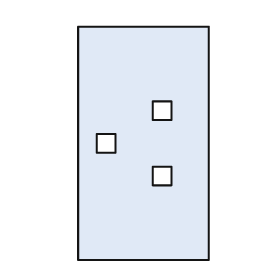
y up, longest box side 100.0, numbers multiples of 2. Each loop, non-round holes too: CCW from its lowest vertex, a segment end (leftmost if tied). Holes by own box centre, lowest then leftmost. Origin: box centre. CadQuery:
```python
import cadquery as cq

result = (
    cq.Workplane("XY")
    .moveTo(-28.0, -50.0)
    .lineTo(28.0, -50.0)
    .lineTo(28.0, 50.0)
    .lineTo(-28.0, 50.0)
    .close()
    .moveTo(4.0, -18.0)
    .lineTo(12.0, -18.0)
    .lineTo(12.0, -10.0)
    .lineTo(4.0, -10.0)
    .close()
    .moveTo(-20.0, -4.0)
    .lineTo(-12.0, -4.0)
    .lineTo(-12.0, 4.0)
    .lineTo(-20.0, 4.0)
    .close()
    .moveTo(4.0, 10.0)
    .lineTo(12.0, 10.0)
    .lineTo(12.0, 18.0)
    .lineTo(4.0, 18.0)
    .close()
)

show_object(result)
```